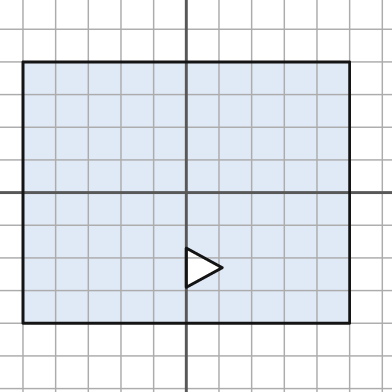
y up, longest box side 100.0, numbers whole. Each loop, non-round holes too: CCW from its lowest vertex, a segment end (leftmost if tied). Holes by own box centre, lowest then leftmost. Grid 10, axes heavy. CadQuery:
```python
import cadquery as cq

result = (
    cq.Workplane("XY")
    .moveTo(-50.0, -40.0)
    .lineTo(50.0, -40.0)
    .lineTo(50.0, 40.0)
    .lineTo(-50.0, 40.0)
    .close()
    .moveTo(0.0, -29.0)
    .lineTo(11.0, -23.0)
    .lineTo(0.0, -17.0)
    .close()
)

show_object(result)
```